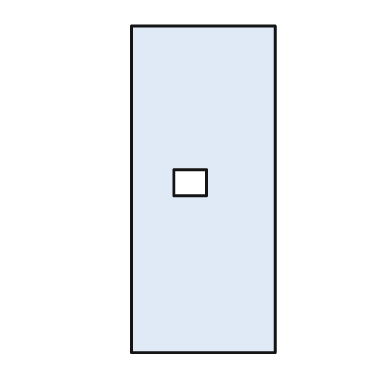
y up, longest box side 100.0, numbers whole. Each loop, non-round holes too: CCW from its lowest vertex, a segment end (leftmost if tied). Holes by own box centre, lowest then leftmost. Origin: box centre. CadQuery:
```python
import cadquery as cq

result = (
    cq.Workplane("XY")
    .moveTo(-22.0, -50.0)
    .lineTo(22.0, -50.0)
    .lineTo(22.0, 50.0)
    .lineTo(-22.0, 50.0)
    .close()
    .moveTo(-9.0, -2.0)
    .lineTo(1.0, -2.0)
    .lineTo(1.0, 6.0)
    .lineTo(-9.0, 6.0)
    .close()
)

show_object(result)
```